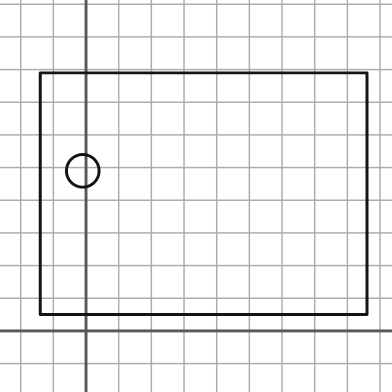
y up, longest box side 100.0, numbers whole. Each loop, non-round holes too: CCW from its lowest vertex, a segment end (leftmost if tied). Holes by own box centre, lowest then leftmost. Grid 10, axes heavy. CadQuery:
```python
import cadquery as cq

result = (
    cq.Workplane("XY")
    .moveTo(-14.0, 5.0)
    .lineTo(86.0, 5.0)
    .lineTo(86.0, 79.0)
    .lineTo(-14.0, 79.0)
    .close()
    .moveTo(-1.0, 49.0)
    .circle(5.0)
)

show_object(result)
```